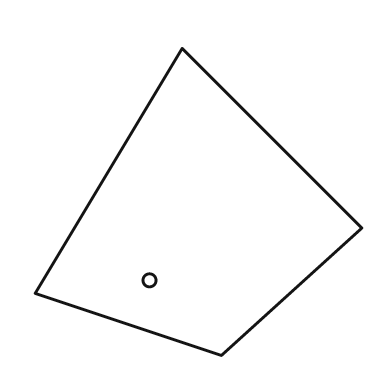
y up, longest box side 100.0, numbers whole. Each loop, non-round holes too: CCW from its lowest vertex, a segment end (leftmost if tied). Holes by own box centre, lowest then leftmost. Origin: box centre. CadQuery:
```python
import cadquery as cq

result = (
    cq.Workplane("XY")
    .moveTo(7.0, -47.0)
    .lineTo(50.0, -8.0)
    .lineTo(-5.0, 47.0)
    .lineTo(-50.0, -28.0)
    .close()
    .moveTo(-15.0, -24.0)
    .circle(2.0)
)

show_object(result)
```